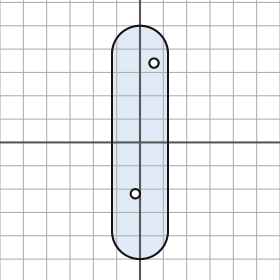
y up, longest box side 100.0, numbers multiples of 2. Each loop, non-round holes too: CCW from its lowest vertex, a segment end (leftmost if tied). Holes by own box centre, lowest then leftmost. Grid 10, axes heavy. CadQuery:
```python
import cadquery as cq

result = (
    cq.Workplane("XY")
    .moveTo(-12.0, -38.0)
    .threePointArc((0.0, -50.0), (12.0, -38.0))
    .lineTo(12.0, 38.0)
    .threePointArc((0.0, 50.0), (-12.0, 38.0))
    .close()
    .moveTo(-2.0, -22.0)
    .circle(2.0)
    .moveTo(6.0, 34.0)
    .circle(2.0)
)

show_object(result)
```